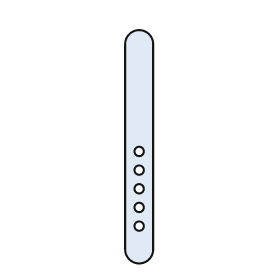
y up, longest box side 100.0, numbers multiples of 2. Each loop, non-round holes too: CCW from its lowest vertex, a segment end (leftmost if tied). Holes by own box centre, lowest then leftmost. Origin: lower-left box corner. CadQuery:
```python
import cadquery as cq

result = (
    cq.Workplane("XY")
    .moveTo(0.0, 6.0)
    .threePointArc((6.0, 0.0), (12.0, 6.0))
    .lineTo(12.0, 94.0)
    .threePointArc((6.0, 100.0), (0.0, 94.0))
    .close()
    .moveTo(6.0, 16.0)
    .circle(2.0)
    .moveTo(6.0, 24.0)
    .circle(2.0)
    .moveTo(6.0, 32.0)
    .circle(2.0)
    .moveTo(6.0, 40.0)
    .circle(2.0)
    .moveTo(6.0, 48.0)
    .circle(2.0)
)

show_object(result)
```